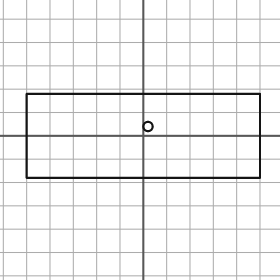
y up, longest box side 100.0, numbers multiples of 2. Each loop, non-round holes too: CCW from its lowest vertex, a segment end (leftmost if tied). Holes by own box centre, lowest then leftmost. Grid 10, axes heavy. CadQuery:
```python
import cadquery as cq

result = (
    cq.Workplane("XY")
    .moveTo(-50.0, -18.0)
    .lineTo(50.0, -18.0)
    .lineTo(50.0, 18.0)
    .lineTo(-50.0, 18.0)
    .close()
    .moveTo(2.0, 4.0)
    .circle(2.0)
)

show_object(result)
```